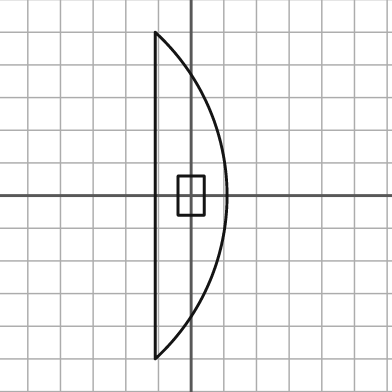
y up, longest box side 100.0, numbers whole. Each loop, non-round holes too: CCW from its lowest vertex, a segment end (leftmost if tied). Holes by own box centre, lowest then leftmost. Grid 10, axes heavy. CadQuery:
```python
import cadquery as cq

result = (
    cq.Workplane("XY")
    .moveTo(-11.0, -50.0)
    .threePointArc((11.0, 0.0), (-11.0, 50.0))
    .close()
    .moveTo(-4.0, -6.0)
    .lineTo(4.0, -6.0)
    .lineTo(4.0, 6.0)
    .lineTo(-4.0, 6.0)
    .close()
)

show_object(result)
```